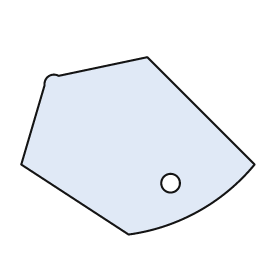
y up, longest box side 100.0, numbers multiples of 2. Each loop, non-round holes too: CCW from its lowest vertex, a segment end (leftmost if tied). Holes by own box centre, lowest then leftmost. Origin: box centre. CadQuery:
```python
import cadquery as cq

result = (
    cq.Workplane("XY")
    .moveTo(-4.0, -38.0)
    .threePointArc((26.0, -28.0), (50.0, -8.0))
    .lineTo(4.0, 38.0)
    .lineTo(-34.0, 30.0)
    .threePointArc((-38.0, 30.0), (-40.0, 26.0))
    .lineTo(-50.0, -8.0)
    .close()
    .moveTo(14.0, -16.0)
    .circle(4.0)
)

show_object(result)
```